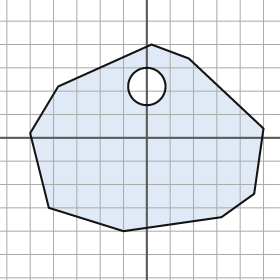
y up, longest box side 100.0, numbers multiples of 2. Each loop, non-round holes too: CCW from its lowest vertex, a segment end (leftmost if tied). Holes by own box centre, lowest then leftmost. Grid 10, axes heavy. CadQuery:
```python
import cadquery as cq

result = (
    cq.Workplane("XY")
    .moveTo(-10.0, -40.0)
    .lineTo(32.0, -34.0)
    .lineTo(46.0, -24.0)
    .lineTo(50.0, 4.0)
    .lineTo(18.0, 34.0)
    .lineTo(2.0, 40.0)
    .lineTo(-38.0, 22.0)
    .lineTo(-50.0, 2.0)
    .lineTo(-42.0, -30.0)
    .close()
    .moveTo(0.0, 22.0)
    .circle(8.0)
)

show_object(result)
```